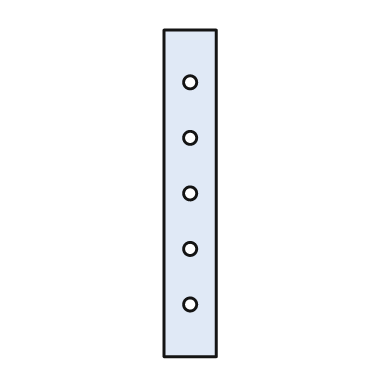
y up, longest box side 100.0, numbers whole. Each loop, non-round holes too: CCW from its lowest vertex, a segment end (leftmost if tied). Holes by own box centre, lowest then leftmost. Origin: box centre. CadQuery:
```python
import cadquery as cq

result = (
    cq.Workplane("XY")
    .moveTo(-8.0, -50.0)
    .lineTo(8.0, -50.0)
    .lineTo(8.0, 50.0)
    .lineTo(-8.0, 50.0)
    .close()
    .moveTo(0.0, -34.0)
    .circle(2.0)
    .moveTo(0.0, -17.0)
    .circle(2.0)
    .moveTo(0.0, 0.0)
    .circle(2.0)
    .moveTo(0.0, 17.0)
    .circle(2.0)
    .moveTo(0.0, 34.0)
    .circle(2.0)
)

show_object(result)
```